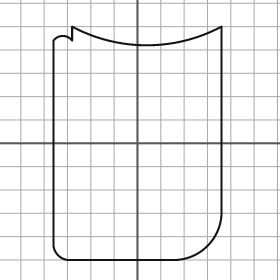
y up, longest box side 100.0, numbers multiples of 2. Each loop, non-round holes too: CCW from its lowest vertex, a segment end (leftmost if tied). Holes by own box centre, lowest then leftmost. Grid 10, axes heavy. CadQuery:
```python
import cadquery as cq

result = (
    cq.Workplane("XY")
    .moveTo(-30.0, -50.0)
    .lineTo(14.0, -50.0)
    .threePointArc((30.0, -44.0), (36.0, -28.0))
    .lineTo(36.0, 50.0)
    .threePointArc((4.0, 42.0), (-28.0, 50.0))
    .lineTo(-28.0, 44.0)
    .threePointArc((-32.0, 46.0), (-36.0, 44.0))
    .lineTo(-36.0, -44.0)
    .threePointArc((-34.0, -48.0), (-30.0, -50.0))
    .close()
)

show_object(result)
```